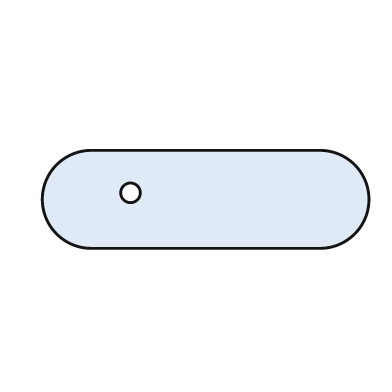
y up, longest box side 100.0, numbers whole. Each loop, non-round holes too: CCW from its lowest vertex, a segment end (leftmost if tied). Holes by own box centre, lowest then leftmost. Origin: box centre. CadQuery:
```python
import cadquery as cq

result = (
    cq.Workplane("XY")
    .moveTo(-35.0, -15.0)
    .lineTo(35.0, -15.0)
    .threePointArc((50.0, 0.0), (35.0, 15.0))
    .lineTo(-35.0, 15.0)
    .threePointArc((-50.0, 0.0), (-35.0, -15.0))
    .close()
    .moveTo(-23.0, 2.0)
    .circle(3.0)
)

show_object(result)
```